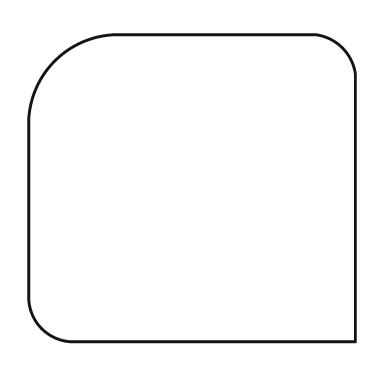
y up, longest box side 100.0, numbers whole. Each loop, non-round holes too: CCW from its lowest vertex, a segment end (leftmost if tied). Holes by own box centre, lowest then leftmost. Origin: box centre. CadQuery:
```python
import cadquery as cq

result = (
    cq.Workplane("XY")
    .moveTo(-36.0, -47.0)
    .lineTo(50.0, -47.0)
    .lineTo(50.0, 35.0)
    .threePointArc((46.0, 43.0), (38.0, 47.0))
    .lineTo(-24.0, 47.0)
    .threePointArc((-42.0, 39.0), (-50.0, 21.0))
    .lineTo(-50.0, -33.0)
    .threePointArc((-46.0, -43.0), (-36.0, -47.0))
    .close()
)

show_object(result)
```